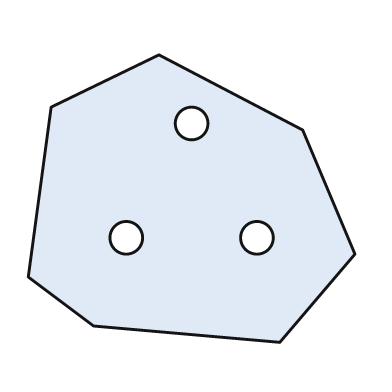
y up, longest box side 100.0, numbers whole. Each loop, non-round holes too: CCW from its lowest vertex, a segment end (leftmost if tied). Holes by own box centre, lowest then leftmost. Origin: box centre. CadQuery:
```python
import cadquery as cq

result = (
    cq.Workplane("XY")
    .moveTo(27.0, -44.0)
    .lineTo(50.0, -17.0)
    .lineTo(34.0, 21.0)
    .lineTo(-10.0, 44.0)
    .lineTo(-43.0, 28.0)
    .lineTo(-50.0, -24.0)
    .lineTo(-30.0, -39.0)
    .close()
    .moveTo(-20.0, -12.0)
    .circle(5.0)
    .moveTo(20.0, -12.0)
    .circle(5.0)
    .moveTo(0.0, 23.0)
    .circle(5.0)
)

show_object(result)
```